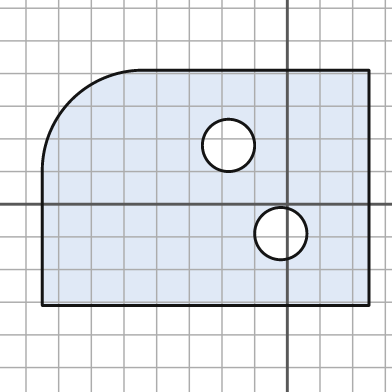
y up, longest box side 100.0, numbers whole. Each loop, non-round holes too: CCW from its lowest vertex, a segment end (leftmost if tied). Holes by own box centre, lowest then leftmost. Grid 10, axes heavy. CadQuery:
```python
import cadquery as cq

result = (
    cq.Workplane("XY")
    .moveTo(-75.0, -31.0)
    .lineTo(25.0, -31.0)
    .lineTo(25.0, 41.0)
    .lineTo(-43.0, 41.0)
    .threePointArc((-66.0, 32.0), (-75.0, 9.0))
    .close()
    .moveTo(-2.0, -9.0)
    .circle(8.0)
    .moveTo(-18.0, 18.0)
    .circle(8.0)
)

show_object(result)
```